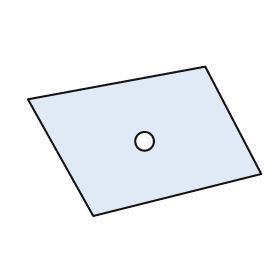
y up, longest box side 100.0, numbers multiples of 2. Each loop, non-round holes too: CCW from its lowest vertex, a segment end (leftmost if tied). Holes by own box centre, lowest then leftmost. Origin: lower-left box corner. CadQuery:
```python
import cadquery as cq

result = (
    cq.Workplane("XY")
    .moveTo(28.0, 0.0)
    .lineTo(100.0, 18.0)
    .lineTo(76.0, 64.0)
    .lineTo(0.0, 50.0)
    .close()
    .moveTo(50.0, 32.0)
    .circle(4.0)
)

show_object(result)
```